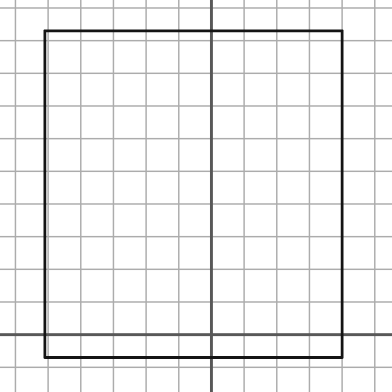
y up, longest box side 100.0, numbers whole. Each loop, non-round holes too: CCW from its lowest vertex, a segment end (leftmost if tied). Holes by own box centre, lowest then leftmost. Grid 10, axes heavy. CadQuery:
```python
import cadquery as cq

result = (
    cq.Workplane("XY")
    .moveTo(-51.0, -7.0)
    .lineTo(40.0, -7.0)
    .lineTo(40.0, 93.0)
    .lineTo(-51.0, 93.0)
    .close()
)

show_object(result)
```